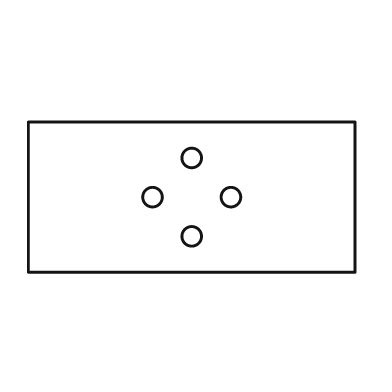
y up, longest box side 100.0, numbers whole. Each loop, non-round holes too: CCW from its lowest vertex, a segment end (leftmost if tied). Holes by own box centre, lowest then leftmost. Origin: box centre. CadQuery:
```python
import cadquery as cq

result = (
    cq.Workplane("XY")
    .moveTo(-50.0, -23.0)
    .lineTo(50.0, -23.0)
    .lineTo(50.0, 23.0)
    .lineTo(-50.0, 23.0)
    .close()
    .moveTo(0.0, -12.0)
    .circle(3.0)
    .moveTo(-12.0, 0.0)
    .circle(3.0)
    .moveTo(12.0, 0.0)
    .circle(3.0)
    .moveTo(0.0, 12.0)
    .circle(3.0)
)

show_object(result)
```